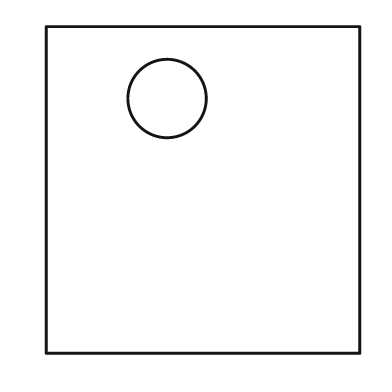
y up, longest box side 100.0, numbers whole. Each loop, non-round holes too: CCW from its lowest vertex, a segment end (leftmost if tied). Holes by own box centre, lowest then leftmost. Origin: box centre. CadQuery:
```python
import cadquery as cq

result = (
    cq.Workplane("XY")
    .moveTo(-48.0, -50.0)
    .lineTo(48.0, -50.0)
    .lineTo(48.0, 50.0)
    .lineTo(-48.0, 50.0)
    .close()
    .moveTo(-11.0, 28.0)
    .circle(12.0)
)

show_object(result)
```